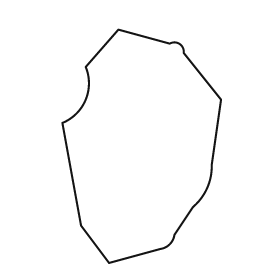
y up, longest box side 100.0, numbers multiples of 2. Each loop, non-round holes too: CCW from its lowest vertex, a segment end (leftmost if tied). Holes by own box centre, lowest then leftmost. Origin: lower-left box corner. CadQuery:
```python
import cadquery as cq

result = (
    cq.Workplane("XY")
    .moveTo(20.0, 0.0)
    .lineTo(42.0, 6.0)
    .threePointArc((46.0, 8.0), (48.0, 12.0))
    .lineTo(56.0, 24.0)
    .threePointArc((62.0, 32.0), (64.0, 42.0))
    .lineTo(68.0, 70.0)
    .lineTo(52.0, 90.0)
    .threePointArc((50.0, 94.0), (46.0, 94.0))
    .lineTo(24.0, 100.0)
    .lineTo(10.0, 84.0)
    .threePointArc((10.0, 70.0), (0.0, 60.0))
    .lineTo(8.0, 16.0)
    .close()
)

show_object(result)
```